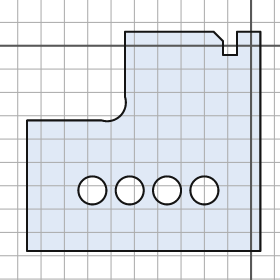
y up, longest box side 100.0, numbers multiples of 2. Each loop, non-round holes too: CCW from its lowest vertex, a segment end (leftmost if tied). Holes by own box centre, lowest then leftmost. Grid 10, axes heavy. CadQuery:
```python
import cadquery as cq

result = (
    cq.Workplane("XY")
    .moveTo(-96.0, -88.0)
    .lineTo(4.0, -88.0)
    .lineTo(4.0, 6.0)
    .lineTo(-6.0, 6.0)
    .lineTo(-6.0, -4.0)
    .lineTo(-12.0, -4.0)
    .lineTo(-12.0, 2.0)
    .lineTo(-16.0, 6.0)
    .lineTo(-54.0, 6.0)
    .lineTo(-54.0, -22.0)
    .threePointArc((-56.0, -30.0), (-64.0, -32.0))
    .lineTo(-96.0, -32.0)
    .close()
    .moveTo(-68.0, -62.0)
    .circle(6.0)
    .moveTo(-52.0, -62.0)
    .circle(6.0)
    .moveTo(-36.0, -62.0)
    .circle(6.0)
    .moveTo(-20.0, -62.0)
    .circle(6.0)
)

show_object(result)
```